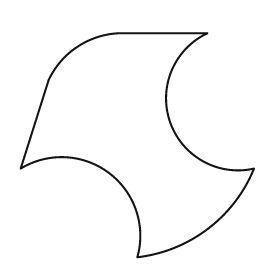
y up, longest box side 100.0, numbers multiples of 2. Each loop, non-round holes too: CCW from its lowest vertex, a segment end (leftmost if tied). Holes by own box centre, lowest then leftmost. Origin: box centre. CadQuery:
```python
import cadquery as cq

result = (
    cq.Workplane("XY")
    .moveTo(0.0, -48.0)
    .threePointArc((30.0, -36.0), (50.0, -10.0))
    .threePointArc((14.0, 10.0), (30.0, 48.0))
    .lineTo(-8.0, 48.0)
    .threePointArc((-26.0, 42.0), (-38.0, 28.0))
    .lineTo(-50.0, -10.0)
    .threePointArc((-12.0, -12.0), (0.0, -48.0))
    .close()
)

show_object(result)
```